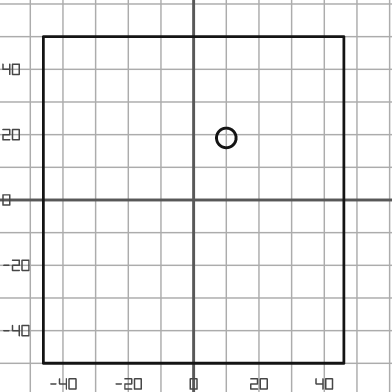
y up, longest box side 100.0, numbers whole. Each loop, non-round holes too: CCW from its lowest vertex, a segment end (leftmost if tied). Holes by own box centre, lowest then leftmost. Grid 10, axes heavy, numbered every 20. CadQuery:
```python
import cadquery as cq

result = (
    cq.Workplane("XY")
    .moveTo(-46.0, -50.0)
    .lineTo(46.0, -50.0)
    .lineTo(46.0, 50.0)
    .lineTo(-46.0, 50.0)
    .close()
    .moveTo(10.0, 19.0)
    .circle(3.0)
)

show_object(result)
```